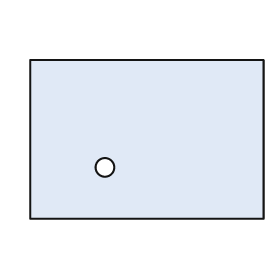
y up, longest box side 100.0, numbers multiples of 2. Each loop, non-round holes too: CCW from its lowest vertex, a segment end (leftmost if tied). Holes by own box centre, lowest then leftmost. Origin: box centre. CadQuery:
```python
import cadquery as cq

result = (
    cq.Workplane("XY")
    .moveTo(-50.0, -34.0)
    .lineTo(50.0, -34.0)
    .lineTo(50.0, 34.0)
    .lineTo(-50.0, 34.0)
    .close()
    .moveTo(-18.0, -12.0)
    .circle(4.0)
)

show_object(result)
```